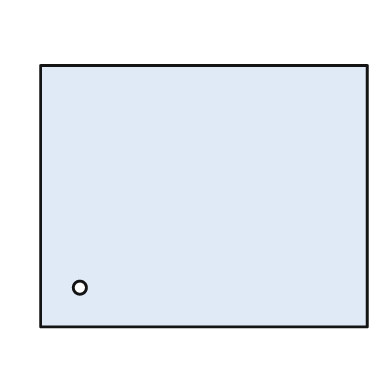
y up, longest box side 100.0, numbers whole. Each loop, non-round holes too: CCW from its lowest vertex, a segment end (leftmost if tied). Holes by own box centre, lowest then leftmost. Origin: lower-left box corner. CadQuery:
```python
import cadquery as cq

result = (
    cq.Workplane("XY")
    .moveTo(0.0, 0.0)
    .lineTo(100.0, 0.0)
    .lineTo(100.0, 80.0)
    .lineTo(0.0, 80.0)
    .close()
    .moveTo(12.0, 12.0)
    .circle(2.0)
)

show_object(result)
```